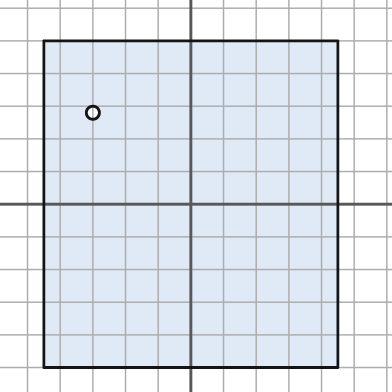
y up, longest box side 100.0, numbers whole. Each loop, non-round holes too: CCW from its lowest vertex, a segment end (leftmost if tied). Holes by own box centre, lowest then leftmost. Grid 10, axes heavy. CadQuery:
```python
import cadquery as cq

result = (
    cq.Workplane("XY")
    .moveTo(-45.0, -50.0)
    .lineTo(45.0, -50.0)
    .lineTo(45.0, 50.0)
    .lineTo(-45.0, 50.0)
    .close()
    .moveTo(-30.0, 28.0)
    .circle(2.0)
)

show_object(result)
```